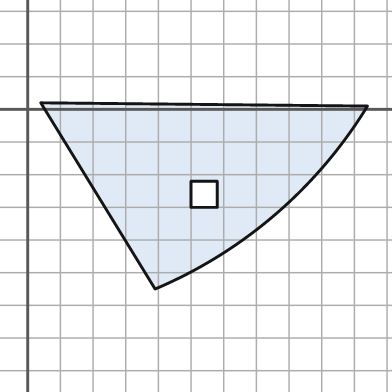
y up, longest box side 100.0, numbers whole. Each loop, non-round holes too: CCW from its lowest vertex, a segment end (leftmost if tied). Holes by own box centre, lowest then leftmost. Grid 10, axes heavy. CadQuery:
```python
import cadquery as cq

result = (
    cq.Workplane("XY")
    .moveTo(39.0, -55.0)
    .threePointArc((76.0, -32.0), (104.0, 1.0))
    .lineTo(4.0, 2.0)
    .close()
    .moveTo(50.0, -30.0)
    .lineTo(58.0, -30.0)
    .lineTo(58.0, -22.0)
    .lineTo(50.0, -22.0)
    .close()
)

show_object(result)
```